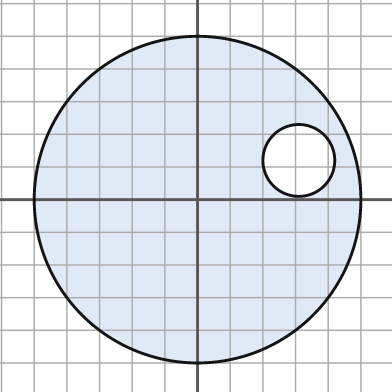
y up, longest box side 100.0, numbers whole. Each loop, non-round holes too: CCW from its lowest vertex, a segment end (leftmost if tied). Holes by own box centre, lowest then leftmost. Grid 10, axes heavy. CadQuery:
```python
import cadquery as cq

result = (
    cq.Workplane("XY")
    .moveTo(0.0, 0.0)
    .circle(50.0)
    .moveTo(31.0, 12.0)
    .circle(11.0)
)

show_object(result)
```